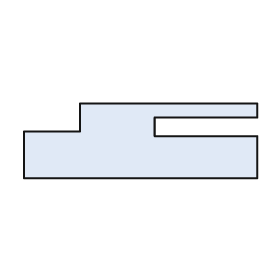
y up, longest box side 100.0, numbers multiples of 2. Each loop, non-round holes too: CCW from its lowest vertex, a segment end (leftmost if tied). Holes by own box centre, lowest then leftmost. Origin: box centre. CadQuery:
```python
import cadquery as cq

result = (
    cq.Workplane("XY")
    .moveTo(-50.0, -16.0)
    .lineTo(50.0, -16.0)
    .lineTo(50.0, 2.0)
    .lineTo(6.0, 2.0)
    .lineTo(6.0, 10.0)
    .lineTo(50.0, 10.0)
    .lineTo(50.0, 16.0)
    .lineTo(-26.0, 16.0)
    .lineTo(-26.0, 4.0)
    .lineTo(-50.0, 4.0)
    .close()
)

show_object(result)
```